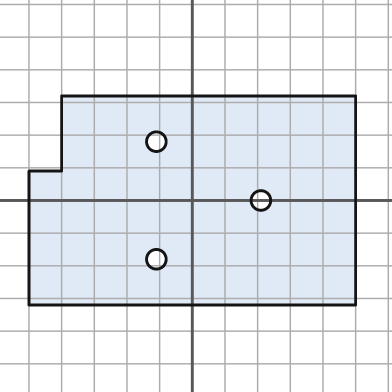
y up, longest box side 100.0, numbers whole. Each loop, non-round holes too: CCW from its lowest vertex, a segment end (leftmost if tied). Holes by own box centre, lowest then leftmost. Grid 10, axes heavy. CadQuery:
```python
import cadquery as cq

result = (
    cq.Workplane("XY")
    .moveTo(-50.0, -32.0)
    .lineTo(50.0, -32.0)
    .lineTo(50.0, 32.0)
    .lineTo(-40.0, 32.0)
    .lineTo(-40.0, 9.0)
    .lineTo(-50.0, 9.0)
    .close()
    .moveTo(-11.0, -18.0)
    .circle(3.0)
    .moveTo(21.0, 0.0)
    .circle(3.0)
    .moveTo(-11.0, 18.0)
    .circle(3.0)
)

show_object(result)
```